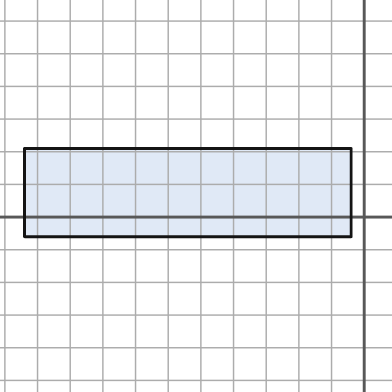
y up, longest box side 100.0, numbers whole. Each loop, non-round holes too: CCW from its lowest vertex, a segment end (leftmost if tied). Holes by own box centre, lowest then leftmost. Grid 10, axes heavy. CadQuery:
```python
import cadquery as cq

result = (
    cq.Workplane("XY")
    .moveTo(-104.0, -6.0)
    .lineTo(-4.0, -6.0)
    .lineTo(-4.0, 21.0)
    .lineTo(-104.0, 21.0)
    .close()
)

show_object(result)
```